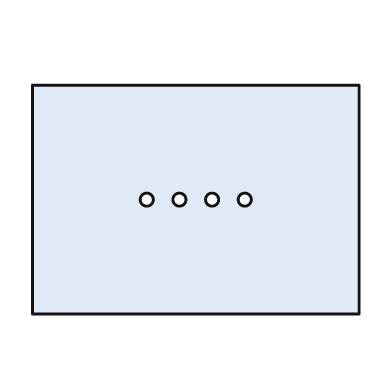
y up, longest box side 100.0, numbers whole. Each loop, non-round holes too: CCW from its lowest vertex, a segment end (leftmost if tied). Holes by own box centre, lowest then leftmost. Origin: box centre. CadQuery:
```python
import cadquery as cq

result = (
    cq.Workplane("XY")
    .moveTo(-50.0, -35.0)
    .lineTo(50.0, -35.0)
    .lineTo(50.0, 35.0)
    .lineTo(-50.0, 35.0)
    .close()
    .moveTo(-15.0, 0.0)
    .circle(2.0)
    .moveTo(-5.0, 0.0)
    .circle(2.0)
    .moveTo(5.0, 0.0)
    .circle(2.0)
    .moveTo(15.0, 0.0)
    .circle(2.0)
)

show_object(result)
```